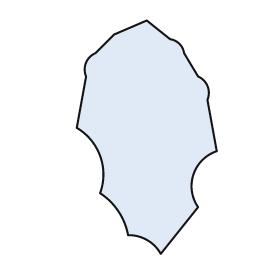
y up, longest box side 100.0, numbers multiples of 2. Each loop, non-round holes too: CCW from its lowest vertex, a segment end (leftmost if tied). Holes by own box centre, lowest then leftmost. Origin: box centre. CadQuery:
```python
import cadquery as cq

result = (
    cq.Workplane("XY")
    .moveTo(6.0, -50.0)
    .lineTo(22.0, -30.0)
    .threePointArc((20.0, -16.0), (30.0, -6.0))
    .lineTo(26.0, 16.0)
    .threePointArc((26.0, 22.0), (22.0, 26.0))
    .lineTo(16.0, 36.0)
    .threePointArc((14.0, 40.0), (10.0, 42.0))
    .lineTo(0.0, 50.0)
    .lineTo(-14.0, 44.0)
    .lineTo(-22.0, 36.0)
    .threePointArc((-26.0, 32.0), (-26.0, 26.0))
    .lineTo(-30.0, 4.0)
    .threePointArc((-20.0, -8.0), (-20.0, -24.0))
    .threePointArc((-12.0, -32.0), (-8.0, -42.0))
    .threePointArc((0.0, -44.0), (6.0, -50.0))
    .close()
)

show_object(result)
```